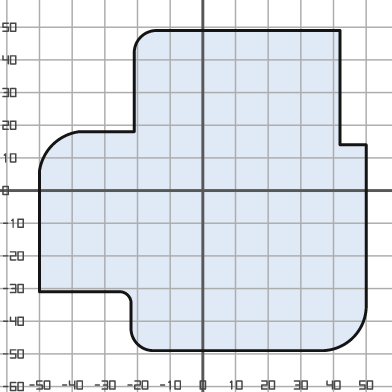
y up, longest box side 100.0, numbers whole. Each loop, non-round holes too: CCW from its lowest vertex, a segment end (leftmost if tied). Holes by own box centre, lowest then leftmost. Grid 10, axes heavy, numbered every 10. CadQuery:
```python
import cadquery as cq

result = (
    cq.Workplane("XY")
    .moveTo(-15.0, -49.0)
    .lineTo(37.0, -49.0)
    .threePointArc((46.0, -45.0), (50.0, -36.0))
    .lineTo(50.0, 14.0)
    .lineTo(42.0, 14.0)
    .lineTo(42.0, 49.0)
    .lineTo(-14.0, 49.0)
    .threePointArc((-19.0, 47.0), (-21.0, 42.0))
    .lineTo(-21.0, 18.0)
    .lineTo(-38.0, 18.0)
    .threePointArc((-46.0, 14.0), (-50.0, 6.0))
    .lineTo(-50.0, -31.0)
    .lineTo(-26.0, -31.0)
    .threePointArc((-23.0, -32.0), (-22.0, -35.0))
    .lineTo(-22.0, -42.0)
    .threePointArc((-20.0, -47.0), (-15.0, -49.0))
    .close()
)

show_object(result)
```